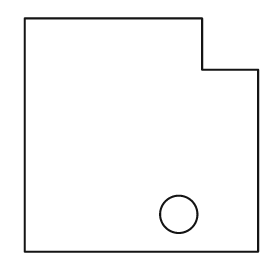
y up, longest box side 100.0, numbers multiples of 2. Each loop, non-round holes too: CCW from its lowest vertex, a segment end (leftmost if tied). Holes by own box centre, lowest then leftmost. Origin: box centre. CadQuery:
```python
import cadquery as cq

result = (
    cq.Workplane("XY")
    .moveTo(-50.0, -50.0)
    .lineTo(50.0, -50.0)
    .lineTo(50.0, 28.0)
    .lineTo(26.0, 28.0)
    .lineTo(26.0, 50.0)
    .lineTo(-50.0, 50.0)
    .close()
    .moveTo(16.0, -34.0)
    .circle(8.0)
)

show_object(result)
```